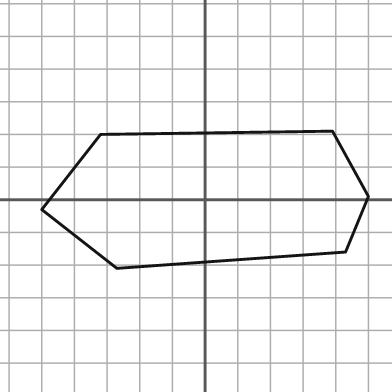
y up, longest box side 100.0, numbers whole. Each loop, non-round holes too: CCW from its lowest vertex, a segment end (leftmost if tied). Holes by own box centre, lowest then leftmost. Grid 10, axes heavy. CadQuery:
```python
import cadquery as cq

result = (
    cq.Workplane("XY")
    .moveTo(-27.0, -21.0)
    .lineTo(43.0, -16.0)
    .lineTo(50.0, 1.0)
    .lineTo(39.0, 21.0)
    .lineTo(-32.0, 20.0)
    .lineTo(-50.0, -3.0)
    .close()
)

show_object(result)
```